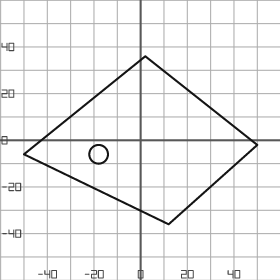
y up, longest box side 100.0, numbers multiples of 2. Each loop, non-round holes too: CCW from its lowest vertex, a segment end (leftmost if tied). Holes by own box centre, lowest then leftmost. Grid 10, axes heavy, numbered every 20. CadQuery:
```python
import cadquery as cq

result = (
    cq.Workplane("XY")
    .moveTo(12.0, -36.0)
    .lineTo(50.0, -2.0)
    .lineTo(2.0, 36.0)
    .lineTo(-50.0, -6.0)
    .close()
    .moveTo(-18.0, -6.0)
    .circle(4.0)
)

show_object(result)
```